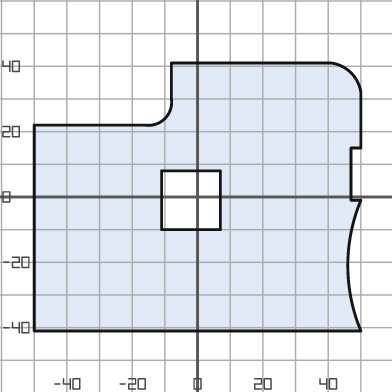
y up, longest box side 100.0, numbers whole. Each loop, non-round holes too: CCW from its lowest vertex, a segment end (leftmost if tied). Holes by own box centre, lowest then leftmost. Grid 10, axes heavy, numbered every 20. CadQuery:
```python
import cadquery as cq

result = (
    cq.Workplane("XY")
    .moveTo(-50.0, -41.0)
    .lineTo(50.0, -41.0)
    .threePointArc((46.0, -21.0), (50.0, -1.0))
    .lineTo(47.0, -1.0)
    .lineTo(47.0, 15.0)
    .lineTo(50.0, 15.0)
    .lineTo(50.0, 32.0)
    .threePointArc((47.0, 38.0), (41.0, 41.0))
    .lineTo(-8.0, 41.0)
    .lineTo(-8.0, 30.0)
    .threePointArc((-10.0, 24.0), (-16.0, 22.0))
    .lineTo(-50.0, 22.0)
    .close()
    .moveTo(-11.0, -10.0)
    .lineTo(7.0, -10.0)
    .lineTo(7.0, 8.0)
    .lineTo(-11.0, 8.0)
    .close()
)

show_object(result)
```